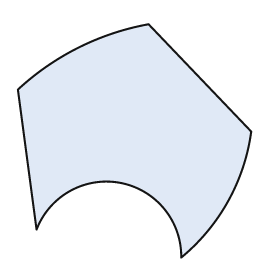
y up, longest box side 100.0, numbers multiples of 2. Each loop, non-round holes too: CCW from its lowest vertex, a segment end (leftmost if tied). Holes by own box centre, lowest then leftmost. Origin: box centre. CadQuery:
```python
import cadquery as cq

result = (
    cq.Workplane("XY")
    .moveTo(20.0, -50.0)
    .threePointArc((40.0, -26.0), (50.0, 4.0))
    .lineTo(6.0, 50.0)
    .threePointArc((-24.0, 40.0), (-50.0, 22.0))
    .lineTo(-42.0, -38.0)
    .threePointArc((-6.0, -18.0), (20.0, -50.0))
    .close()
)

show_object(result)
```